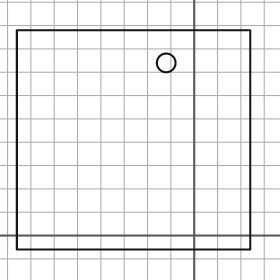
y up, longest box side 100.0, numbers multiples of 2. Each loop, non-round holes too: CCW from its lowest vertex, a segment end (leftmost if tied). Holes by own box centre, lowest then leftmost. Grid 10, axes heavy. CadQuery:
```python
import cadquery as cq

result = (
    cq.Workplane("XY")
    .moveTo(-76.0, -6.0)
    .lineTo(24.0, -6.0)
    .lineTo(24.0, 88.0)
    .lineTo(-76.0, 88.0)
    .close()
    .moveTo(-12.0, 74.0)
    .circle(4.0)
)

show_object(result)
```